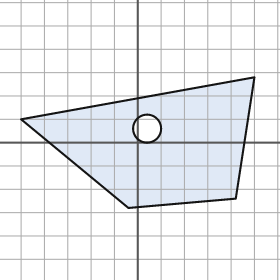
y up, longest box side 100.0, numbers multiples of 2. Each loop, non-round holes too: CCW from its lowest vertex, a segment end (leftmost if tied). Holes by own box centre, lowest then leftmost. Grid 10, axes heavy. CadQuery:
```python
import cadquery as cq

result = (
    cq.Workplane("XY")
    .moveTo(-4.0, -28.0)
    .lineTo(42.0, -24.0)
    .lineTo(50.0, 28.0)
    .lineTo(-50.0, 10.0)
    .close()
    .moveTo(4.0, 6.0)
    .circle(6.0)
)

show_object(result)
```